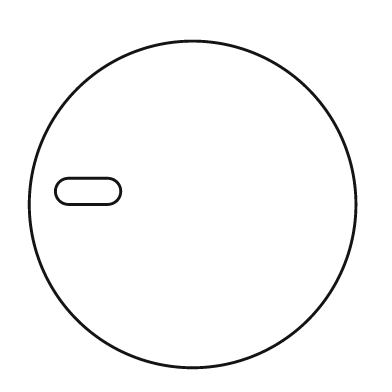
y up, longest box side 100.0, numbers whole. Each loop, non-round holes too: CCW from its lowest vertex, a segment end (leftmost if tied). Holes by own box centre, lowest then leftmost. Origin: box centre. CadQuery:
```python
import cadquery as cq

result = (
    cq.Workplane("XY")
    .moveTo(0.0, 0.0)
    .circle(50.0)
    .moveTo(-38.0, 0.0)
    .lineTo(-26.0, 0.0)
    .threePointArc((-22.0, 4.0), (-26.0, 8.0))
    .lineTo(-38.0, 8.0)
    .threePointArc((-42.0, 4.0), (-38.0, 0.0))
    .close()
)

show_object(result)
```